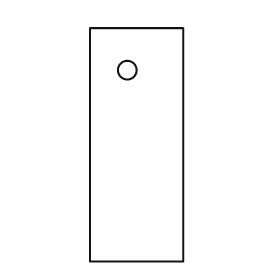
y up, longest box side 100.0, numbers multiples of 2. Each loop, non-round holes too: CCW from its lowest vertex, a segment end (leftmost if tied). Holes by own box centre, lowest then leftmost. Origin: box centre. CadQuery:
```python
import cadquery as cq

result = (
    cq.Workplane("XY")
    .moveTo(-20.0, -50.0)
    .lineTo(20.0, -50.0)
    .lineTo(20.0, 50.0)
    .lineTo(-20.0, 50.0)
    .close()
    .moveTo(-4.0, 32.0)
    .circle(4.0)
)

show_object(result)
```